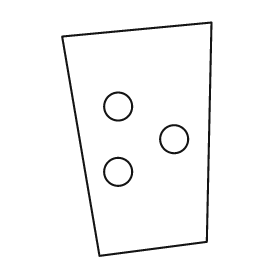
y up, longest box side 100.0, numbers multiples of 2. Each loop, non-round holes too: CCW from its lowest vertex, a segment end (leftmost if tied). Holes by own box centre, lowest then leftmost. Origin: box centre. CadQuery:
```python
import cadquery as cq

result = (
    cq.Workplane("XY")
    .moveTo(-16.0, -50.0)
    .lineTo(30.0, -44.0)
    .lineTo(32.0, 50.0)
    .lineTo(-32.0, 44.0)
    .close()
    .moveTo(-8.0, -14.0)
    .circle(6.0)
    .moveTo(16.0, 0.0)
    .circle(6.0)
    .moveTo(-8.0, 14.0)
    .circle(6.0)
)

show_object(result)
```